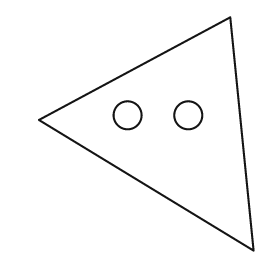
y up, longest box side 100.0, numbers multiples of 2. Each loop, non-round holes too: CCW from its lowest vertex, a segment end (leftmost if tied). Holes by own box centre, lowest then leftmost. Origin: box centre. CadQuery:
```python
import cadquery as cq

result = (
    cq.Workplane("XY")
    .moveTo(46.0, -50.0)
    .lineTo(36.0, 50.0)
    .lineTo(-46.0, 6.0)
    .close()
    .moveTo(-8.0, 8.0)
    .circle(6.0)
    .moveTo(18.0, 8.0)
    .circle(6.0)
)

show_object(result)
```